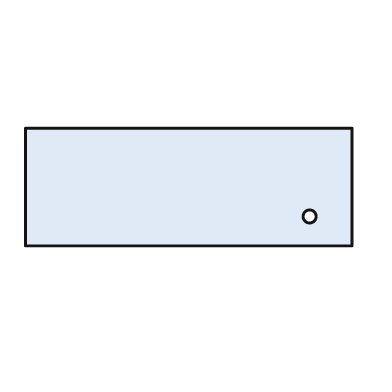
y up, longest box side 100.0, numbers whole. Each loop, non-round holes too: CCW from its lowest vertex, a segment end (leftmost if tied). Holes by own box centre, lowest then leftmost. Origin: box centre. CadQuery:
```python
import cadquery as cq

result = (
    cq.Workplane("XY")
    .moveTo(-50.0, -18.0)
    .lineTo(50.0, -18.0)
    .lineTo(50.0, 18.0)
    .lineTo(-50.0, 18.0)
    .close()
    .moveTo(37.0, -9.0)
    .circle(2.0)
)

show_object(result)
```